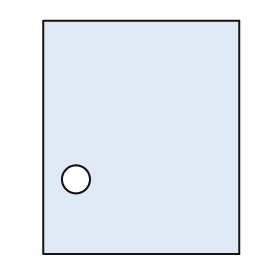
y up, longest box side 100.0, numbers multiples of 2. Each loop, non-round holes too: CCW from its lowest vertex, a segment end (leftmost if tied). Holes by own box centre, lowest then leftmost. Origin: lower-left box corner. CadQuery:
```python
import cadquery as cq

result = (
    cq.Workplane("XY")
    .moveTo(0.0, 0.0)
    .lineTo(84.0, 0.0)
    .lineTo(84.0, 100.0)
    .lineTo(0.0, 100.0)
    .close()
    .moveTo(14.0, 32.0)
    .circle(6.0)
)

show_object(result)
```